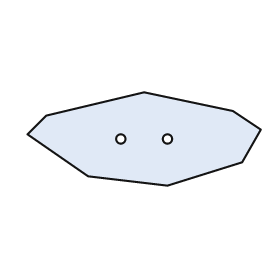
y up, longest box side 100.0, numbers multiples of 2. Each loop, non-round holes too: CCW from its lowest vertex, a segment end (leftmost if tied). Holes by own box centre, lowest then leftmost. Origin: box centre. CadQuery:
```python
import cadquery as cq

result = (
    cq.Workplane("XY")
    .moveTo(10.0, -20.0)
    .lineTo(42.0, -10.0)
    .lineTo(50.0, 4.0)
    .lineTo(38.0, 12.0)
    .lineTo(0.0, 20.0)
    .lineTo(-42.0, 10.0)
    .lineTo(-50.0, 2.0)
    .lineTo(-24.0, -16.0)
    .close()
    .moveTo(-10.0, 0.0)
    .circle(2.0)
    .moveTo(10.0, 0.0)
    .circle(2.0)
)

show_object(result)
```